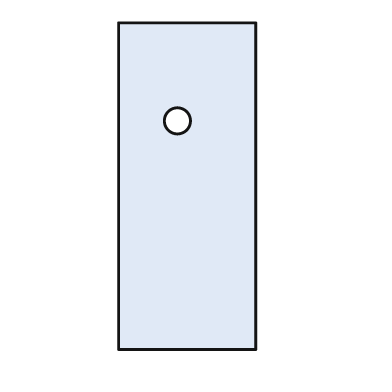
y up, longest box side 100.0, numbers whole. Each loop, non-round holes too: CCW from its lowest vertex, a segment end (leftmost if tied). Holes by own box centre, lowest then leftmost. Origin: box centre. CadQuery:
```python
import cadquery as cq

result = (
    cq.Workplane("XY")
    .moveTo(-21.0, -50.0)
    .lineTo(21.0, -50.0)
    .lineTo(21.0, 50.0)
    .lineTo(-21.0, 50.0)
    .close()
    .moveTo(-3.0, 20.0)
    .circle(4.0)
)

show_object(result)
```